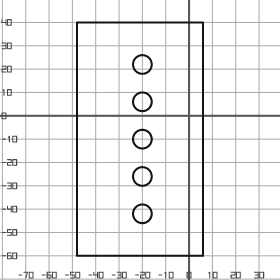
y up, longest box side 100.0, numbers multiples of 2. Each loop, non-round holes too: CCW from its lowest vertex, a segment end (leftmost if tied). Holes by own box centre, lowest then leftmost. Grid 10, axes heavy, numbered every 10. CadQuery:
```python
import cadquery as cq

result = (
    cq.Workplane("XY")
    .moveTo(-48.0, -60.0)
    .lineTo(6.0, -60.0)
    .lineTo(6.0, 40.0)
    .lineTo(-48.0, 40.0)
    .close()
    .moveTo(-20.0, -42.0)
    .circle(4.0)
    .moveTo(-20.0, -26.0)
    .circle(4.0)
    .moveTo(-20.0, -10.0)
    .circle(4.0)
    .moveTo(-20.0, 6.0)
    .circle(4.0)
    .moveTo(-20.0, 22.0)
    .circle(4.0)
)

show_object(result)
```